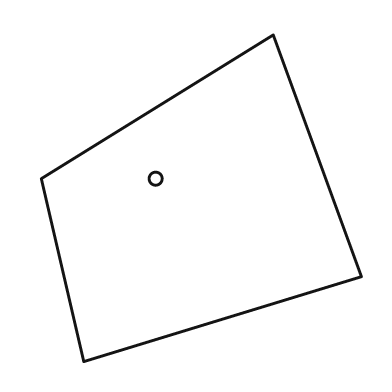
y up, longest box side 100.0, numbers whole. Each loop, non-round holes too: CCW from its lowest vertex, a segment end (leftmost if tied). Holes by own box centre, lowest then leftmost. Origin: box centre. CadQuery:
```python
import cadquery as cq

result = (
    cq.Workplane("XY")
    .moveTo(-36.0, -50.0)
    .lineTo(49.0, -24.0)
    .lineTo(22.0, 50.0)
    .lineTo(-49.0, 6.0)
    .close()
    .moveTo(-14.0, 6.0)
    .circle(2.0)
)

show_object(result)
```